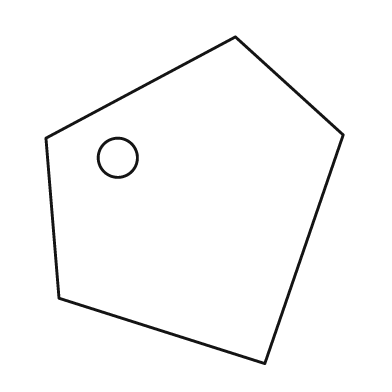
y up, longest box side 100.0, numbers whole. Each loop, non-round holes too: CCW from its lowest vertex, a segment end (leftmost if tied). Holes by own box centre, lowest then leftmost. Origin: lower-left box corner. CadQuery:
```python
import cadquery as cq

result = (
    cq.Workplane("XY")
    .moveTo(67.0, 0.0)
    .lineTo(91.0, 70.0)
    .lineTo(58.0, 100.0)
    .lineTo(0.0, 69.0)
    .lineTo(4.0, 20.0)
    .close()
    .moveTo(22.0, 63.0)
    .circle(6.0)
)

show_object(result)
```